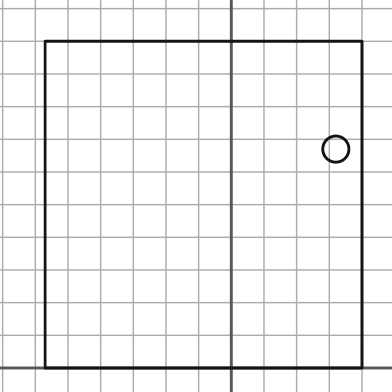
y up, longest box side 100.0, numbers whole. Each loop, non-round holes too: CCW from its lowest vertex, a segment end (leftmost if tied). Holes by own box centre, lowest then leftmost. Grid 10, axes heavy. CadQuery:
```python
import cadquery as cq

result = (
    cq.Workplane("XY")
    .moveTo(-57.0, 0.0)
    .lineTo(40.0, 0.0)
    .lineTo(40.0, 100.0)
    .lineTo(-57.0, 100.0)
    .close()
    .moveTo(32.0, 67.0)
    .circle(4.0)
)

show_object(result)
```